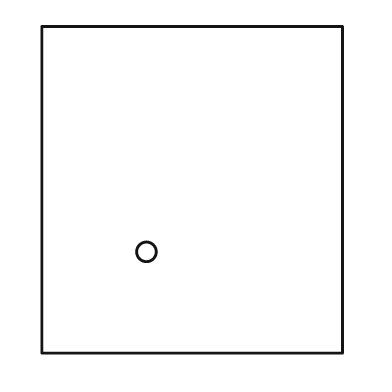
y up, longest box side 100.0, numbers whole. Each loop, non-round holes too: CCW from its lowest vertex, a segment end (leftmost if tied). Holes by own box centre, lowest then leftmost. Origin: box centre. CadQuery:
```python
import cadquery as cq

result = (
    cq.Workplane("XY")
    .moveTo(-46.0, -50.0)
    .lineTo(46.0, -50.0)
    .lineTo(46.0, 50.0)
    .lineTo(-46.0, 50.0)
    .close()
    .moveTo(-14.0, -19.0)
    .circle(3.0)
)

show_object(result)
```